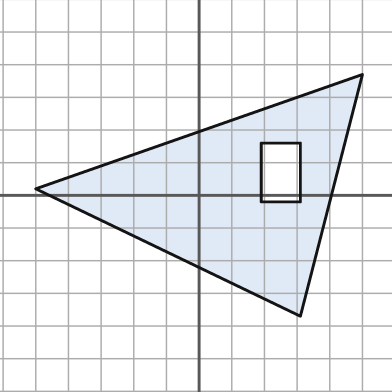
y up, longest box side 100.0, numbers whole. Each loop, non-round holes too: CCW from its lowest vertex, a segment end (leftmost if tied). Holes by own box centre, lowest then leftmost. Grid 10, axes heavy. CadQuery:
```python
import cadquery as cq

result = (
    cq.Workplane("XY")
    .moveTo(31.0, -37.0)
    .lineTo(50.0, 37.0)
    .lineTo(-50.0, 2.0)
    .close()
    .moveTo(19.0, -2.0)
    .lineTo(31.0, -2.0)
    .lineTo(31.0, 16.0)
    .lineTo(19.0, 16.0)
    .close()
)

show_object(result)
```